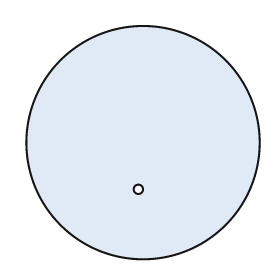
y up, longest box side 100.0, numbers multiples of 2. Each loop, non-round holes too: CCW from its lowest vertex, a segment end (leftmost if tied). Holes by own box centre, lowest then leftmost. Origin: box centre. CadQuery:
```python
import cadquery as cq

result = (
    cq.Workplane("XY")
    .moveTo(0.0, 0.0)
    .circle(50.0)
    .moveTo(-2.0, -20.0)
    .circle(2.0)
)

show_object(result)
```